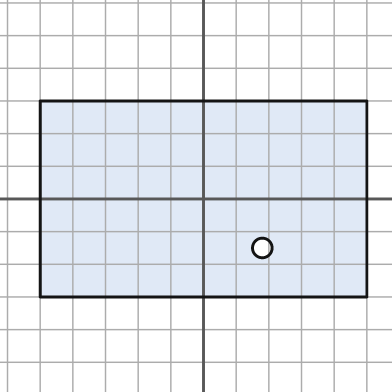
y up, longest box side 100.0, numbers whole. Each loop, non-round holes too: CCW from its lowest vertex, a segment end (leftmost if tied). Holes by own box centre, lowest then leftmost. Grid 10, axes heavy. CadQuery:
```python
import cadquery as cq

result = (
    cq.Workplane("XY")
    .moveTo(-50.0, -30.0)
    .lineTo(50.0, -30.0)
    .lineTo(50.0, 30.0)
    .lineTo(-50.0, 30.0)
    .close()
    .moveTo(18.0, -15.0)
    .circle(3.0)
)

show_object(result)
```